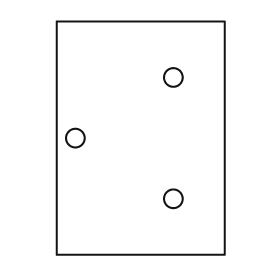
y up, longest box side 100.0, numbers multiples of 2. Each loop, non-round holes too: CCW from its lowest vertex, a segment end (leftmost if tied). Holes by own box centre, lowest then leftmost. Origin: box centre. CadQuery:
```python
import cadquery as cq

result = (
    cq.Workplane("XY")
    .moveTo(-36.0, -50.0)
    .lineTo(36.0, -50.0)
    .lineTo(36.0, 50.0)
    .lineTo(-36.0, 50.0)
    .close()
    .moveTo(14.0, -26.0)
    .circle(4.0)
    .moveTo(-28.0, 0.0)
    .circle(4.0)
    .moveTo(14.0, 26.0)
    .circle(4.0)
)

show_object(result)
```